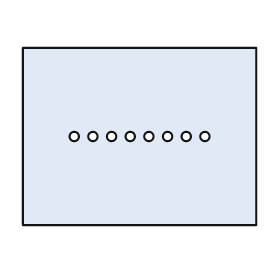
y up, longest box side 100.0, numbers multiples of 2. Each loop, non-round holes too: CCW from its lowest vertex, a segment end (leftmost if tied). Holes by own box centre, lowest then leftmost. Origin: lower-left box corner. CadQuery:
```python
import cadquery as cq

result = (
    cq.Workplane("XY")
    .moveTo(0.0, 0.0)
    .lineTo(100.0, 0.0)
    .lineTo(100.0, 76.0)
    .lineTo(0.0, 76.0)
    .close()
    .moveTo(22.0, 38.0)
    .circle(2.0)
    .moveTo(30.0, 38.0)
    .circle(2.0)
    .moveTo(38.0, 38.0)
    .circle(2.0)
    .moveTo(46.0, 38.0)
    .circle(2.0)
    .moveTo(54.0, 38.0)
    .circle(2.0)
    .moveTo(62.0, 38.0)
    .circle(2.0)
    .moveTo(70.0, 38.0)
    .circle(2.0)
    .moveTo(78.0, 38.0)
    .circle(2.0)
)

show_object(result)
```